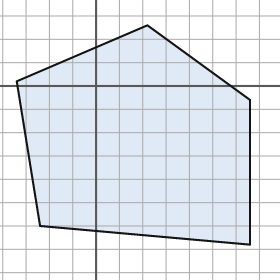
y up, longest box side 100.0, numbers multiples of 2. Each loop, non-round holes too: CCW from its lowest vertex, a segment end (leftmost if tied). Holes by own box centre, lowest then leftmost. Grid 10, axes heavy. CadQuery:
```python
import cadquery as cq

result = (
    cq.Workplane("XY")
    .moveTo(66.0, -68.0)
    .lineTo(66.0, -6.0)
    .lineTo(22.0, 26.0)
    .lineTo(-34.0, 2.0)
    .lineTo(-24.0, -60.0)
    .close()
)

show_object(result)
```